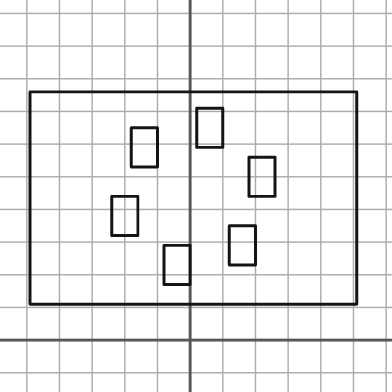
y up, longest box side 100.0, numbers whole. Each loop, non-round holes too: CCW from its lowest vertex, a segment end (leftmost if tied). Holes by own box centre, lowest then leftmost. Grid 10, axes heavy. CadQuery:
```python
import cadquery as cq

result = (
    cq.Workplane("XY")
    .moveTo(-49.0, 11.0)
    .lineTo(51.0, 11.0)
    .lineTo(51.0, 76.0)
    .lineTo(-49.0, 76.0)
    .close()
    .moveTo(-8.0, 17.0)
    .lineTo(0.0, 17.0)
    .lineTo(0.0, 29.0)
    .lineTo(-8.0, 29.0)
    .close()
    .moveTo(12.0, 23.0)
    .lineTo(20.0, 23.0)
    .lineTo(20.0, 35.0)
    .lineTo(12.0, 35.0)
    .close()
    .moveTo(-24.0, 32.0)
    .lineTo(-16.0, 32.0)
    .lineTo(-16.0, 44.0)
    .lineTo(-24.0, 44.0)
    .close()
    .moveTo(18.0, 44.0)
    .lineTo(26.0, 44.0)
    .lineTo(26.0, 56.0)
    .lineTo(18.0, 56.0)
    .close()
    .moveTo(-18.0, 53.0)
    .lineTo(-10.0, 53.0)
    .lineTo(-10.0, 65.0)
    .lineTo(-18.0, 65.0)
    .close()
    .moveTo(2.0, 59.0)
    .lineTo(10.0, 59.0)
    .lineTo(10.0, 71.0)
    .lineTo(2.0, 71.0)
    .close()
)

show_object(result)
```